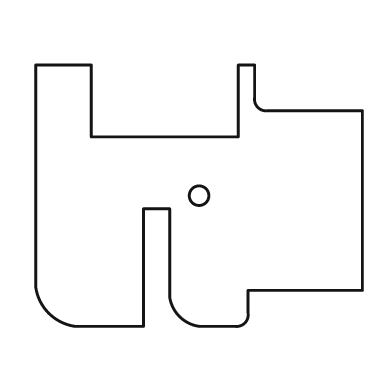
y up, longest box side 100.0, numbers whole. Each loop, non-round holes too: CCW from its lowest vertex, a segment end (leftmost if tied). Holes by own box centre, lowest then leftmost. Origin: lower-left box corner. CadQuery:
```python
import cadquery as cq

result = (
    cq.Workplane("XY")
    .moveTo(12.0, 0.0)
    .lineTo(33.0, 0.0)
    .lineTo(33.0, 36.0)
    .lineTo(41.0, 36.0)
    .lineTo(41.0, 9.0)
    .threePointArc((44.0, 3.0), (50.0, 0.0))
    .lineTo(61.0, 0.0)
    .threePointArc((64.0, 1.0), (65.0, 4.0))
    .lineTo(65.0, 11.0)
    .lineTo(100.0, 11.0)
    .lineTo(100.0, 66.0)
    .lineTo(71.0, 66.0)
    .threePointArc((68.0, 67.0), (67.0, 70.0))
    .lineTo(67.0, 80.0)
    .lineTo(62.0, 80.0)
    .lineTo(62.0, 58.0)
    .lineTo(17.0, 58.0)
    .lineTo(17.0, 80.0)
    .lineTo(0.0, 80.0)
    .lineTo(0.0, 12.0)
    .threePointArc((4.0, 4.0), (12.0, 0.0))
    .close()
    .moveTo(50.0, 40.0)
    .circle(3.0)
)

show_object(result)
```